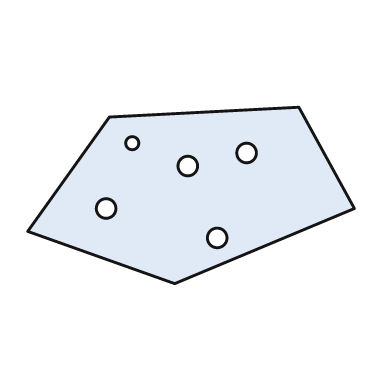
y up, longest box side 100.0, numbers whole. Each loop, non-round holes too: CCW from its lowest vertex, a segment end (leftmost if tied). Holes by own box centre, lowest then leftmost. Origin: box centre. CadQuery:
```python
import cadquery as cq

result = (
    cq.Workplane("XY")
    .moveTo(-5.0, -27.0)
    .lineTo(50.0, -4.0)
    .lineTo(33.0, 27.0)
    .lineTo(-25.0, 24.0)
    .lineTo(-50.0, -11.0)
    .close()
    .moveTo(8.0, -13.0)
    .circle(3.0)
    .moveTo(-26.0, -4.0)
    .circle(3.0)
    .moveTo(-1.0, 9.0)
    .circle(3.0)
    .moveTo(17.0, 13.0)
    .circle(3.0)
    .moveTo(-18.0, 16.0)
    .circle(2.0)
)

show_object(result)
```